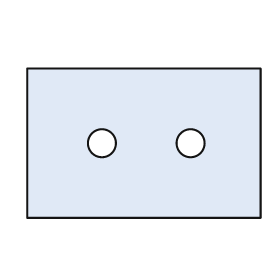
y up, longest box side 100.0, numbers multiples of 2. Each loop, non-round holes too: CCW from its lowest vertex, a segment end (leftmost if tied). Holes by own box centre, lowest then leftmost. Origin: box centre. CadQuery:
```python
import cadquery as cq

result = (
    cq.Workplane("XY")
    .moveTo(-50.0, -32.0)
    .lineTo(50.0, -32.0)
    .lineTo(50.0, 32.0)
    .lineTo(-50.0, 32.0)
    .close()
    .moveTo(-18.0, 0.0)
    .circle(6.0)
    .moveTo(20.0, 0.0)
    .circle(6.0)
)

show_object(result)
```